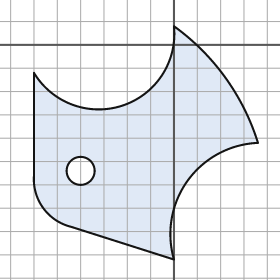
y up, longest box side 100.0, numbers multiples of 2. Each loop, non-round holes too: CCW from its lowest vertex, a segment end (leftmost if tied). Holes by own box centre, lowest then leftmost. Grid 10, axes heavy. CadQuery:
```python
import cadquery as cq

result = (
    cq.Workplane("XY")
    .moveTo(0.0, -92.0)
    .threePointArc((6.0, -58.0), (36.0, -42.0))
    .threePointArc((22.0, -14.0), (0.0, 8.0))
    .threePointArc((-22.0, -26.0), (-60.0, -12.0))
    .lineTo(-60.0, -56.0)
    .threePointArc((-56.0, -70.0), (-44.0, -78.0))
    .close()
    .moveTo(-40.0, -54.0)
    .circle(6.0)
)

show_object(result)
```